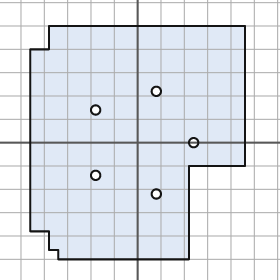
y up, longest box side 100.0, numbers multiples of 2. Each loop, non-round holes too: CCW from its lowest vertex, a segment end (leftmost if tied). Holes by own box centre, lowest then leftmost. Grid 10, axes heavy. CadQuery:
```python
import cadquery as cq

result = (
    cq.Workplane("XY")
    .moveTo(-34.0, -50.0)
    .lineTo(22.0, -50.0)
    .lineTo(22.0, -10.0)
    .lineTo(46.0, -10.0)
    .lineTo(46.0, 50.0)
    .lineTo(-38.0, 50.0)
    .lineTo(-38.0, 40.0)
    .lineTo(-46.0, 40.0)
    .lineTo(-46.0, -38.0)
    .lineTo(-38.0, -38.0)
    .lineTo(-38.0, -46.0)
    .lineTo(-34.0, -46.0)
    .close()
    .moveTo(8.0, -22.0)
    .circle(2.0)
    .moveTo(-18.0, -14.0)
    .circle(2.0)
    .moveTo(24.0, 0.0)
    .circle(2.0)
    .moveTo(-18.0, 14.0)
    .circle(2.0)
    .moveTo(8.0, 22.0)
    .circle(2.0)
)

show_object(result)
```